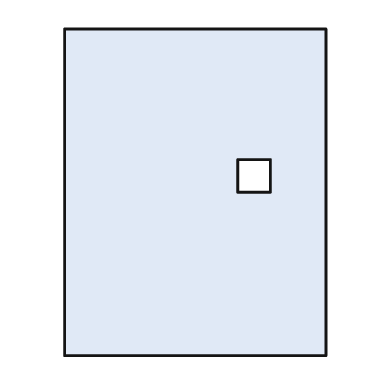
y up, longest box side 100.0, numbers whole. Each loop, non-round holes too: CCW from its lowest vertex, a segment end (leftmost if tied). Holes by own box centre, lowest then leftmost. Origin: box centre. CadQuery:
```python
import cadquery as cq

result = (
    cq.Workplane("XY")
    .moveTo(-40.0, -50.0)
    .lineTo(40.0, -50.0)
    .lineTo(40.0, 50.0)
    .lineTo(-40.0, 50.0)
    .close()
    .moveTo(13.0, 0.0)
    .lineTo(23.0, 0.0)
    .lineTo(23.0, 10.0)
    .lineTo(13.0, 10.0)
    .close()
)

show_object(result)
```